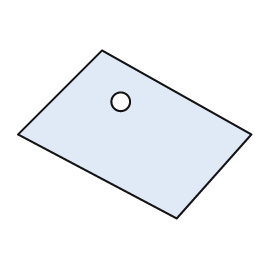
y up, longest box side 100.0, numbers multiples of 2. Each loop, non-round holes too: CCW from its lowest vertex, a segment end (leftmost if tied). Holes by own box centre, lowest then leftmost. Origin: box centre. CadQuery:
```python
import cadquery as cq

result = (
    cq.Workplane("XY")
    .moveTo(18.0, -36.0)
    .lineTo(50.0, 0.0)
    .lineTo(-14.0, 36.0)
    .lineTo(-50.0, 0.0)
    .close()
    .moveTo(-6.0, 14.0)
    .circle(4.0)
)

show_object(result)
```